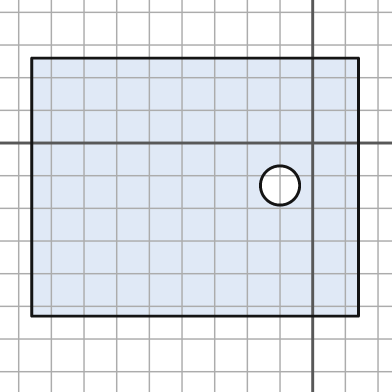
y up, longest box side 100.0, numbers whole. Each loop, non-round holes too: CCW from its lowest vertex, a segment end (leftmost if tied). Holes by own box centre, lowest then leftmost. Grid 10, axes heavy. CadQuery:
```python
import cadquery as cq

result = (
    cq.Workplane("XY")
    .moveTo(-86.0, -53.0)
    .lineTo(14.0, -53.0)
    .lineTo(14.0, 26.0)
    .lineTo(-86.0, 26.0)
    .close()
    .moveTo(-10.0, -13.0)
    .circle(6.0)
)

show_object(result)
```